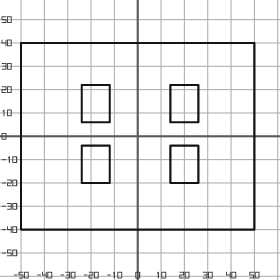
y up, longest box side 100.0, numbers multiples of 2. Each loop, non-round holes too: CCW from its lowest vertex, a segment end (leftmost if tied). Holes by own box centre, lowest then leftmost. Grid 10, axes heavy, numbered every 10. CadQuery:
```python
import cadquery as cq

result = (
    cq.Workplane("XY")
    .moveTo(-50.0, -40.0)
    .lineTo(50.0, -40.0)
    .lineTo(50.0, 40.0)
    .lineTo(-50.0, 40.0)
    .close()
    .moveTo(-24.0, -20.0)
    .lineTo(-12.0, -20.0)
    .lineTo(-12.0, -4.0)
    .lineTo(-24.0, -4.0)
    .close()
    .moveTo(14.0, -20.0)
    .lineTo(26.0, -20.0)
    .lineTo(26.0, -4.0)
    .lineTo(14.0, -4.0)
    .close()
    .moveTo(-24.0, 6.0)
    .lineTo(-12.0, 6.0)
    .lineTo(-12.0, 22.0)
    .lineTo(-24.0, 22.0)
    .close()
    .moveTo(14.0, 6.0)
    .lineTo(26.0, 6.0)
    .lineTo(26.0, 22.0)
    .lineTo(14.0, 22.0)
    .close()
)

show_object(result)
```